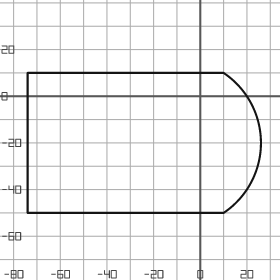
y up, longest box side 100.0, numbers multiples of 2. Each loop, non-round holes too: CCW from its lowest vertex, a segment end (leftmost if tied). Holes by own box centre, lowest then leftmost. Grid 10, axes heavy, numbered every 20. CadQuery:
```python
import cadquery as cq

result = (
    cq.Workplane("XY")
    .moveTo(-74.0, -50.0)
    .lineTo(10.0, -50.0)
    .threePointArc((26.0, -20.0), (10.0, 10.0))
    .lineTo(-74.0, 10.0)
    .close()
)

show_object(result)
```